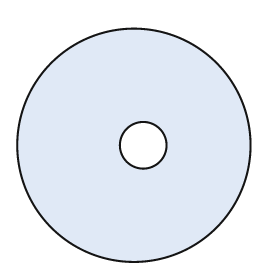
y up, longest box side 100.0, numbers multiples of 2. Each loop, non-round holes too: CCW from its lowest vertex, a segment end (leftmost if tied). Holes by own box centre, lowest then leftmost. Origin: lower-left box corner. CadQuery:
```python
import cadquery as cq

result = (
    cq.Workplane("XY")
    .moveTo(50.0, 50.0)
    .circle(50.0)
    .moveTo(54.0, 50.0)
    .circle(10.0)
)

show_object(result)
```